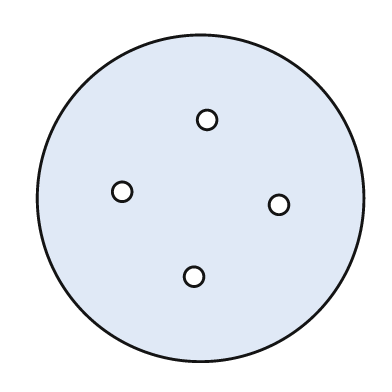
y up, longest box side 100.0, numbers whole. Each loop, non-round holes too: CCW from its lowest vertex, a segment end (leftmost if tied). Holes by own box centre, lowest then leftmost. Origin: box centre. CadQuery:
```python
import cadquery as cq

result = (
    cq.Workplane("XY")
    .moveTo(0.0, 0.0)
    .circle(50.0)
    .moveTo(-2.0, -24.0)
    .circle(3.0)
    .moveTo(24.0, -2.0)
    .circle(3.0)
    .moveTo(-24.0, 2.0)
    .circle(3.0)
    .moveTo(2.0, 24.0)
    .circle(3.0)
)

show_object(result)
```